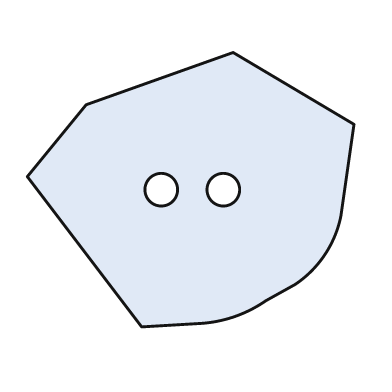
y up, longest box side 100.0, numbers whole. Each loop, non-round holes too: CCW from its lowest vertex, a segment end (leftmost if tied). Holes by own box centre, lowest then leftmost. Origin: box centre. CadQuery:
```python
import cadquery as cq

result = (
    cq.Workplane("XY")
    .moveTo(-15.0, -42.0)
    .lineTo(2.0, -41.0)
    .threePointArc((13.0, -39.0), (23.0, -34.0))
    .lineTo(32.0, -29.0)
    .threePointArc((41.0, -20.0), (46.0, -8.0))
    .lineTo(50.0, 20.0)
    .lineTo(13.0, 42.0)
    .lineTo(-32.0, 26.0)
    .lineTo(-50.0, 4.0)
    .close()
    .moveTo(-9.0, 0.0)
    .circle(5.0)
    .moveTo(10.0, 0.0)
    .circle(5.0)
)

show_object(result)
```